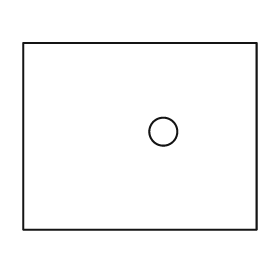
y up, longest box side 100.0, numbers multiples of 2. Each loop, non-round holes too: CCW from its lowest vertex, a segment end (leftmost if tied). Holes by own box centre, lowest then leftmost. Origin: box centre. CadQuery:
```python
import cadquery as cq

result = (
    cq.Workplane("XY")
    .moveTo(-50.0, -40.0)
    .lineTo(50.0, -40.0)
    .lineTo(50.0, 40.0)
    .lineTo(-50.0, 40.0)
    .close()
    .moveTo(10.0, 2.0)
    .circle(6.0)
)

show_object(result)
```